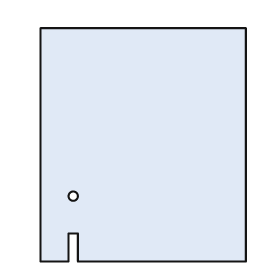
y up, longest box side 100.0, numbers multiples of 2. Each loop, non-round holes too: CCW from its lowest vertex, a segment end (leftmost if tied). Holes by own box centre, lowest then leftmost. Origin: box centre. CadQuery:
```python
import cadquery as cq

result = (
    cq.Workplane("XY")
    .moveTo(-44.0, -50.0)
    .lineTo(-32.0, -50.0)
    .lineTo(-32.0, -38.0)
    .lineTo(-28.0, -38.0)
    .lineTo(-28.0, -50.0)
    .lineTo(44.0, -50.0)
    .lineTo(44.0, 50.0)
    .lineTo(-44.0, 50.0)
    .close()
    .moveTo(-30.0, -22.0)
    .circle(2.0)
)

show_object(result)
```